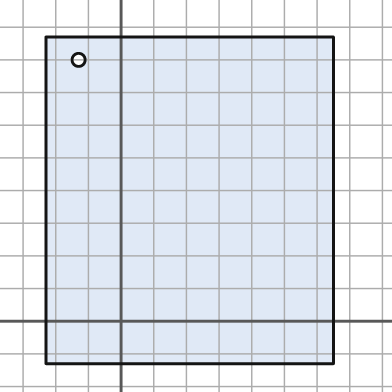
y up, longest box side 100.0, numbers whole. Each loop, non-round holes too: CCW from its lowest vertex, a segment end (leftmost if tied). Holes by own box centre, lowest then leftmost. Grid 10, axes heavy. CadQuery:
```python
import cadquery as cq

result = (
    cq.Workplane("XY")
    .moveTo(-23.0, -13.0)
    .lineTo(65.0, -13.0)
    .lineTo(65.0, 87.0)
    .lineTo(-23.0, 87.0)
    .close()
    .moveTo(-13.0, 80.0)
    .circle(2.0)
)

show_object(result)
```